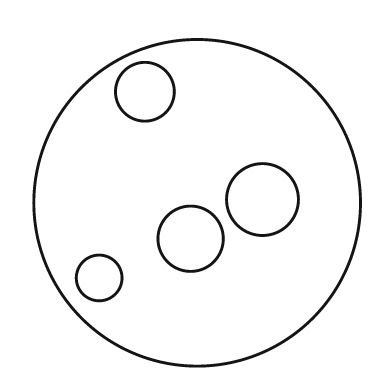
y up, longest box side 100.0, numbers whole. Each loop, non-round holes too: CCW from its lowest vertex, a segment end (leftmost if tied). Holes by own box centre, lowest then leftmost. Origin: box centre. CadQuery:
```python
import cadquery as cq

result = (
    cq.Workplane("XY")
    .moveTo(0.0, 0.0)
    .circle(50.0)
    .moveTo(-30.0, -23.0)
    .circle(7.0)
    .moveTo(-2.0, -11.0)
    .circle(10.0)
    .moveTo(20.0, 1.0)
    .circle(11.0)
    .moveTo(-16.0, 34.0)
    .circle(9.0)
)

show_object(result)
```